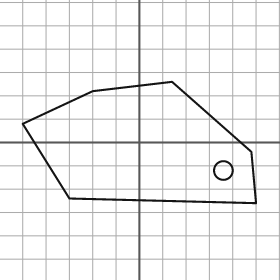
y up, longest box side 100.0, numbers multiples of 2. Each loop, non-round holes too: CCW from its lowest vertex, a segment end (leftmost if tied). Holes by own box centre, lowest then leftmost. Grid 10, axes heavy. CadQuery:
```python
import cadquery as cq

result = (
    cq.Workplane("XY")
    .moveTo(50.0, -26.0)
    .lineTo(48.0, -4.0)
    .lineTo(14.0, 26.0)
    .lineTo(-20.0, 22.0)
    .lineTo(-50.0, 8.0)
    .lineTo(-30.0, -24.0)
    .close()
    .moveTo(36.0, -12.0)
    .circle(4.0)
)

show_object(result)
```